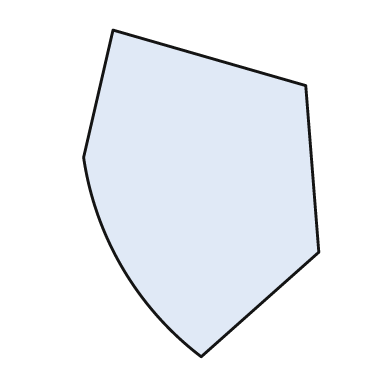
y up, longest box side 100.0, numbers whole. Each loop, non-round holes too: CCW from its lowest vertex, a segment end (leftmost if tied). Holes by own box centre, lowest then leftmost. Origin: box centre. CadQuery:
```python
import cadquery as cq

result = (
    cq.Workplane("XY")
    .moveTo(0.0, -50.0)
    .lineTo(36.0, -18.0)
    .lineTo(32.0, 33.0)
    .lineTo(-27.0, 50.0)
    .lineTo(-36.0, 11.0)
    .threePointArc((-24.0, -23.0), (0.0, -50.0))
    .close()
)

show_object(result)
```